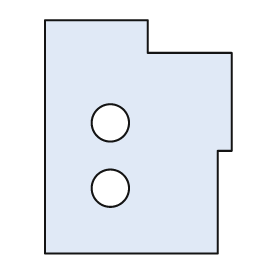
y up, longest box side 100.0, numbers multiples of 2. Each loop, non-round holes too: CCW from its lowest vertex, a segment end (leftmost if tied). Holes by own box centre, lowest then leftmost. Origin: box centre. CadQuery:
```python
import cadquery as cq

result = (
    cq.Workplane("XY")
    .moveTo(-40.0, -50.0)
    .lineTo(34.0, -50.0)
    .lineTo(34.0, -6.0)
    .lineTo(40.0, -6.0)
    .lineTo(40.0, 36.0)
    .lineTo(4.0, 36.0)
    .lineTo(4.0, 50.0)
    .lineTo(-40.0, 50.0)
    .close()
    .moveTo(-12.0, -22.0)
    .circle(8.0)
    .moveTo(-12.0, 6.0)
    .circle(8.0)
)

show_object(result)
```